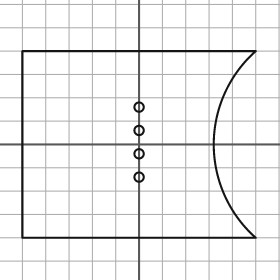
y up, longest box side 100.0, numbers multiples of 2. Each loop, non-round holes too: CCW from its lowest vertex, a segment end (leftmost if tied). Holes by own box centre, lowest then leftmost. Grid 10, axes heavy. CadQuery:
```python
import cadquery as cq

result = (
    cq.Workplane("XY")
    .moveTo(-50.0, -40.0)
    .lineTo(50.0, -40.0)
    .threePointArc((32.0, 0.0), (50.0, 40.0))
    .lineTo(-50.0, 40.0)
    .close()
    .moveTo(0.0, -14.0)
    .circle(2.0)
    .moveTo(0.0, -4.0)
    .circle(2.0)
    .moveTo(0.0, 6.0)
    .circle(2.0)
    .moveTo(0.0, 16.0)
    .circle(2.0)
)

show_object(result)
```